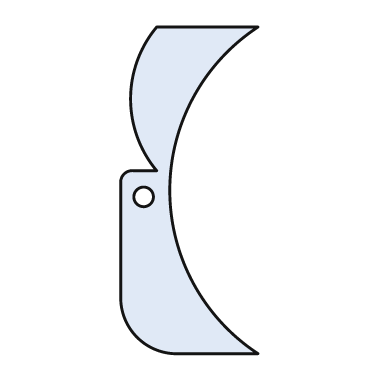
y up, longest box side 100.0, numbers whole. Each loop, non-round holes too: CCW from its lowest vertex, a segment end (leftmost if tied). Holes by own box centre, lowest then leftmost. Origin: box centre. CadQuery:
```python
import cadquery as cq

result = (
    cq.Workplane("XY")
    .moveTo(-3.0, -50.0)
    .lineTo(21.0, -50.0)
    .threePointArc((-6.0, 0.0), (21.0, 50.0))
    .lineTo(-10.0, 50.0)
    .threePointArc((-18.0, 28.0), (-10.0, 6.0))
    .lineTo(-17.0, 6.0)
    .threePointArc((-20.0, 5.0), (-21.0, 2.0))
    .lineTo(-21.0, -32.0)
    .threePointArc((-16.0, -45.0), (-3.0, -50.0))
    .close()
    .moveTo(-14.0, -2.0)
    .circle(3.0)
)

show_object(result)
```